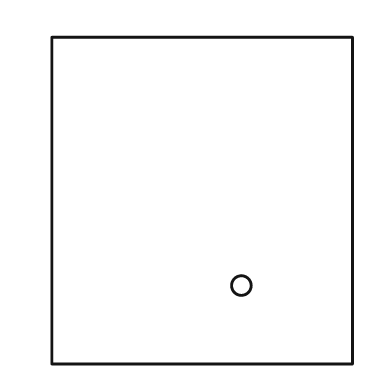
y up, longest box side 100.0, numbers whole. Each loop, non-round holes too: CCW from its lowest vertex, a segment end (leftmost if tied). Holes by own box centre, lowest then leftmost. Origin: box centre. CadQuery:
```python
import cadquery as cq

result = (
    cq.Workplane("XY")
    .moveTo(-46.0, -50.0)
    .lineTo(46.0, -50.0)
    .lineTo(46.0, 50.0)
    .lineTo(-46.0, 50.0)
    .close()
    .moveTo(12.0, -26.0)
    .circle(3.0)
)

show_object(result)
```